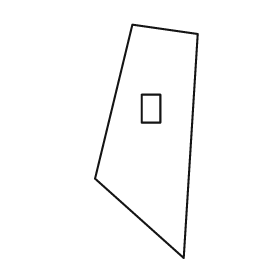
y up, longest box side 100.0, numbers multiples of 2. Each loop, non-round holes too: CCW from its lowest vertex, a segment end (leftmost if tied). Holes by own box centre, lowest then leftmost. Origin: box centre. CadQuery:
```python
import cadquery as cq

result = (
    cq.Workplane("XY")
    .moveTo(16.0, -50.0)
    .lineTo(22.0, 46.0)
    .lineTo(-6.0, 50.0)
    .lineTo(-22.0, -16.0)
    .close()
    .moveTo(-2.0, 8.0)
    .lineTo(6.0, 8.0)
    .lineTo(6.0, 20.0)
    .lineTo(-2.0, 20.0)
    .close()
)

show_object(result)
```